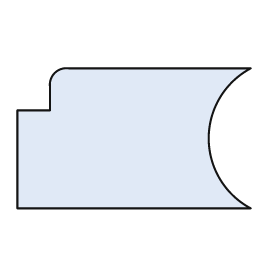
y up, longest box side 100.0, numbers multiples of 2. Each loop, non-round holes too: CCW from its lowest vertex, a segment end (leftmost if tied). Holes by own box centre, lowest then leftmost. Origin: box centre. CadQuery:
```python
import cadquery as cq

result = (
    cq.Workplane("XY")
    .moveTo(-50.0, -30.0)
    .lineTo(50.0, -30.0)
    .threePointArc((32.0, 0.0), (50.0, 30.0))
    .lineTo(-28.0, 30.0)
    .threePointArc((-34.0, 28.0), (-36.0, 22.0))
    .lineTo(-36.0, 12.0)
    .lineTo(-50.0, 12.0)
    .close()
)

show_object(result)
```